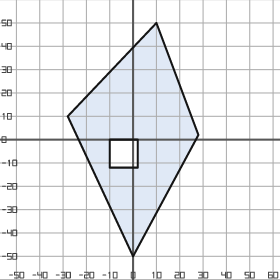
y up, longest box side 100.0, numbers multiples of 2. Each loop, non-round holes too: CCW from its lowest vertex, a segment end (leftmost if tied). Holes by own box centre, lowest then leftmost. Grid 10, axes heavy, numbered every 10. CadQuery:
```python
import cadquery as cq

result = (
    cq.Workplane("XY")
    .moveTo(0.0, -50.0)
    .lineTo(28.0, 2.0)
    .lineTo(10.0, 50.0)
    .lineTo(-28.0, 10.0)
    .close()
    .moveTo(-10.0, -12.0)
    .lineTo(2.0, -12.0)
    .lineTo(2.0, 0.0)
    .lineTo(-10.0, 0.0)
    .close()
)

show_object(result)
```